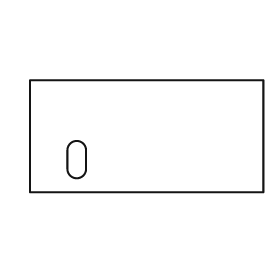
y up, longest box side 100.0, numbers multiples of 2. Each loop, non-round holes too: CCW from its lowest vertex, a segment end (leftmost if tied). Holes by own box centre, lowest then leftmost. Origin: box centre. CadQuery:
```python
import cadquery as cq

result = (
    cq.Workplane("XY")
    .moveTo(-50.0, -24.0)
    .lineTo(50.0, -24.0)
    .lineTo(50.0, 24.0)
    .lineTo(-50.0, 24.0)
    .close()
    .moveTo(-34.0, -14.0)
    .threePointArc((-30.0, -18.0), (-26.0, -14.0))
    .lineTo(-26.0, -6.0)
    .threePointArc((-30.0, -2.0), (-34.0, -6.0))
    .close()
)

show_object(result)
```